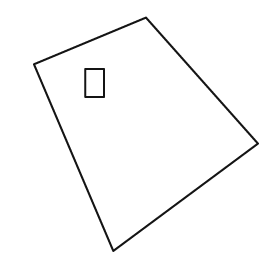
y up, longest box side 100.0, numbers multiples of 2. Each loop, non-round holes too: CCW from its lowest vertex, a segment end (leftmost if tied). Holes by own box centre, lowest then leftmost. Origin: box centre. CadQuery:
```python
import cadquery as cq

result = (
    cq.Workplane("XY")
    .moveTo(-14.0, -50.0)
    .lineTo(48.0, -4.0)
    .lineTo(0.0, 50.0)
    .lineTo(-48.0, 30.0)
    .close()
    .moveTo(-26.0, 16.0)
    .lineTo(-18.0, 16.0)
    .lineTo(-18.0, 28.0)
    .lineTo(-26.0, 28.0)
    .close()
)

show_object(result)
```